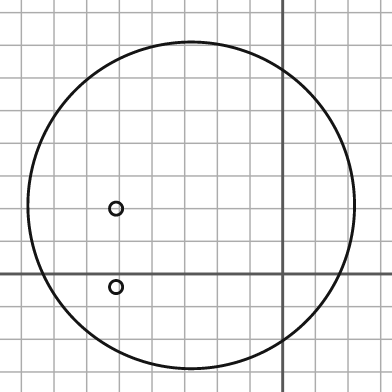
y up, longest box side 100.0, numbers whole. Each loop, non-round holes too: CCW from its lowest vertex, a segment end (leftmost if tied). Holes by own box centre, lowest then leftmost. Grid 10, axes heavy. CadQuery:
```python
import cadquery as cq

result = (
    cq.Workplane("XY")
    .moveTo(-28.0, 21.0)
    .circle(50.0)
    .moveTo(-51.0, -4.0)
    .circle(2.0)
    .moveTo(-51.0, 20.0)
    .circle(2.0)
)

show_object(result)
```